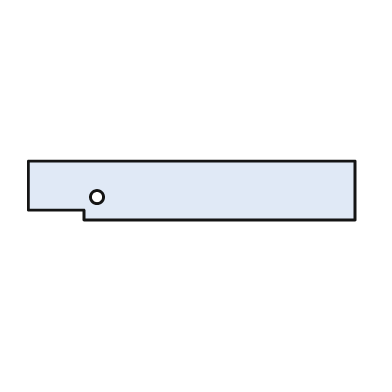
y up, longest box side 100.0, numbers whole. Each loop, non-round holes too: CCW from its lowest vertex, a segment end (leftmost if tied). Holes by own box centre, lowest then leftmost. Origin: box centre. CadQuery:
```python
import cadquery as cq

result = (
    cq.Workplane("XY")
    .moveTo(-33.0, -9.0)
    .lineTo(50.0, -9.0)
    .lineTo(50.0, 9.0)
    .lineTo(-50.0, 9.0)
    .lineTo(-50.0, -6.0)
    .lineTo(-33.0, -6.0)
    .close()
    .moveTo(-29.0, -2.0)
    .circle(2.0)
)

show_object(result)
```